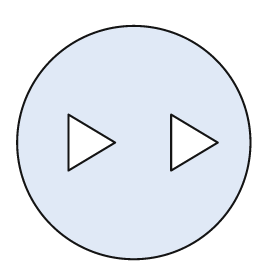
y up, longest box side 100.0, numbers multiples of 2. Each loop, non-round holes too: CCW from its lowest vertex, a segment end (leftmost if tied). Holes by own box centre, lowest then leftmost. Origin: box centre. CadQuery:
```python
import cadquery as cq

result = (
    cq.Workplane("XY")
    .moveTo(0.0, 0.0)
    .circle(50.0)
    .moveTo(-28.0, -12.0)
    .lineTo(-8.0, 0.0)
    .lineTo(-28.0, 12.0)
    .close()
    .moveTo(16.0, -12.0)
    .lineTo(36.0, 0.0)
    .lineTo(16.0, 12.0)
    .close()
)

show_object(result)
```